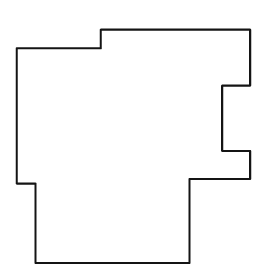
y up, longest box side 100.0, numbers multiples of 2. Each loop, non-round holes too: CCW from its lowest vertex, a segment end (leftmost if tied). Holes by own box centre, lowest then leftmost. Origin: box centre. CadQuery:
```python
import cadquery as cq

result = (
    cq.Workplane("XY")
    .moveTo(-42.0, -50.0)
    .lineTo(24.0, -50.0)
    .lineTo(24.0, -14.0)
    .lineTo(50.0, -14.0)
    .lineTo(50.0, -2.0)
    .lineTo(38.0, -2.0)
    .lineTo(38.0, 26.0)
    .lineTo(50.0, 26.0)
    .lineTo(50.0, 50.0)
    .lineTo(-14.0, 50.0)
    .lineTo(-14.0, 42.0)
    .lineTo(-50.0, 42.0)
    .lineTo(-50.0, -16.0)
    .lineTo(-42.0, -16.0)
    .close()
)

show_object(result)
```